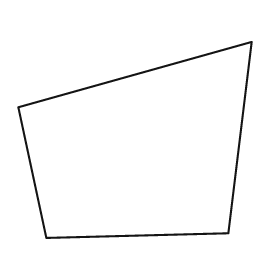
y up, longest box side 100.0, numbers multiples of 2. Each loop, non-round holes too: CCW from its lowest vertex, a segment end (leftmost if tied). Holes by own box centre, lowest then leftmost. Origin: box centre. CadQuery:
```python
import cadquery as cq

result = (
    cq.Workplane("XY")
    .moveTo(-38.0, -42.0)
    .lineTo(40.0, -40.0)
    .lineTo(50.0, 42.0)
    .lineTo(-50.0, 14.0)
    .close()
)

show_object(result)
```